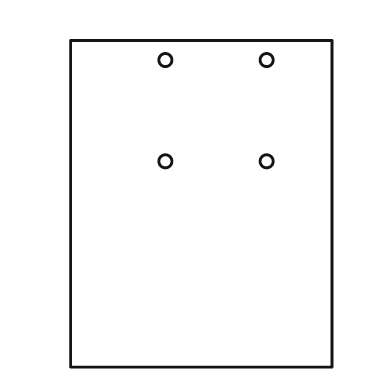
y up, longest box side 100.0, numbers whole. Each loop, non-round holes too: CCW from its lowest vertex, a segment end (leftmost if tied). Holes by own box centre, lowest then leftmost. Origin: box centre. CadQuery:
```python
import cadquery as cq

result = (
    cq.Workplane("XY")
    .moveTo(-40.0, -50.0)
    .lineTo(40.0, -50.0)
    .lineTo(40.0, 50.0)
    .lineTo(-40.0, 50.0)
    .close()
    .moveTo(-11.0, 13.0)
    .circle(2.0)
    .moveTo(20.0, 13.0)
    .circle(2.0)
    .moveTo(-11.0, 44.0)
    .circle(2.0)
    .moveTo(20.0, 44.0)
    .circle(2.0)
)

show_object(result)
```